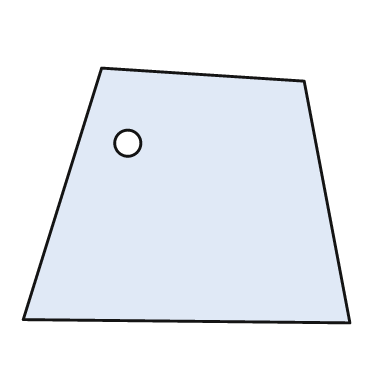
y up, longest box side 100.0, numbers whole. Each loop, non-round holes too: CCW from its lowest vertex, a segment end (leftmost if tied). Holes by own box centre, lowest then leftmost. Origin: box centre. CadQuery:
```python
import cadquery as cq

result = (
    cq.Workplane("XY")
    .moveTo(50.0, -39.0)
    .lineTo(36.0, 35.0)
    .lineTo(-26.0, 39.0)
    .lineTo(-50.0, -38.0)
    .close()
    .moveTo(-18.0, 16.0)
    .circle(4.0)
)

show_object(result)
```